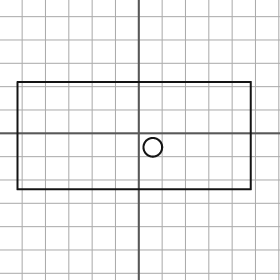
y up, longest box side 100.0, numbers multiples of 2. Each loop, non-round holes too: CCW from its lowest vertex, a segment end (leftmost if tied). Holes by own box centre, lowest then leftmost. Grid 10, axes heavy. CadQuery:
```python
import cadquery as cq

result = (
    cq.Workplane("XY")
    .moveTo(-52.0, -24.0)
    .lineTo(48.0, -24.0)
    .lineTo(48.0, 22.0)
    .lineTo(-52.0, 22.0)
    .close()
    .moveTo(6.0, -6.0)
    .circle(4.0)
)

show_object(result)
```